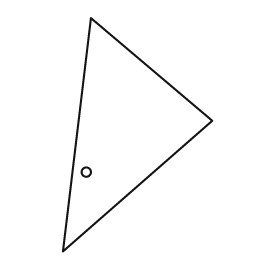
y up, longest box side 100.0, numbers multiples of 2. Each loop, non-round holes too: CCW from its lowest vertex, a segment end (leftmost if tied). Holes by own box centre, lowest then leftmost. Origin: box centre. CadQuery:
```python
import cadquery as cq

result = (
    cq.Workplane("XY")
    .moveTo(-32.0, -50.0)
    .lineTo(32.0, 6.0)
    .lineTo(-20.0, 50.0)
    .close()
    .moveTo(-22.0, -16.0)
    .circle(2.0)
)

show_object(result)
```